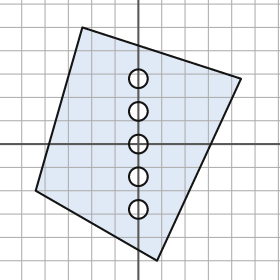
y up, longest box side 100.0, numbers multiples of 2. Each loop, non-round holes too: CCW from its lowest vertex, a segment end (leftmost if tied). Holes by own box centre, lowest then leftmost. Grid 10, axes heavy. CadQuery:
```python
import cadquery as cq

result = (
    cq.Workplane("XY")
    .moveTo(8.0, -50.0)
    .lineTo(44.0, 28.0)
    .lineTo(-24.0, 50.0)
    .lineTo(-44.0, -20.0)
    .close()
    .moveTo(0.0, -28.0)
    .circle(4.0)
    .moveTo(0.0, -14.0)
    .circle(4.0)
    .moveTo(0.0, 0.0)
    .circle(4.0)
    .moveTo(0.0, 14.0)
    .circle(4.0)
    .moveTo(0.0, 28.0)
    .circle(4.0)
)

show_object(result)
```